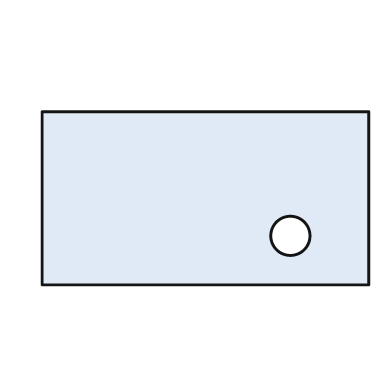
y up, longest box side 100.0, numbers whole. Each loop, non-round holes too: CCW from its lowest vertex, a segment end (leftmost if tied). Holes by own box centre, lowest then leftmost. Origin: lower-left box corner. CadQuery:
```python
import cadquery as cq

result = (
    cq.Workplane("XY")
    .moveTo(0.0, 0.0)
    .lineTo(100.0, 0.0)
    .lineTo(100.0, 53.0)
    .lineTo(0.0, 53.0)
    .close()
    .moveTo(76.0, 15.0)
    .circle(6.0)
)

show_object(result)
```